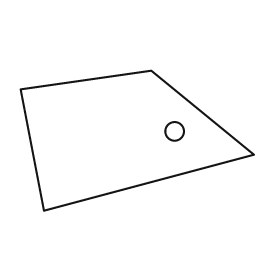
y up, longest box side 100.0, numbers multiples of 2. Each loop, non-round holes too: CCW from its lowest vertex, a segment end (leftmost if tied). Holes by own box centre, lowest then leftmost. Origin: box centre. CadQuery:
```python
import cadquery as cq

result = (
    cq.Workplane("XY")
    .moveTo(-40.0, -30.0)
    .lineTo(50.0, -6.0)
    .lineTo(6.0, 30.0)
    .lineTo(-50.0, 22.0)
    .close()
    .moveTo(16.0, 4.0)
    .circle(4.0)
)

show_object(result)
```